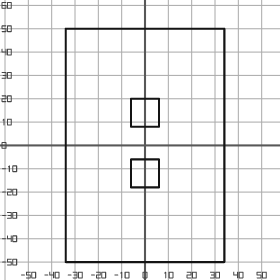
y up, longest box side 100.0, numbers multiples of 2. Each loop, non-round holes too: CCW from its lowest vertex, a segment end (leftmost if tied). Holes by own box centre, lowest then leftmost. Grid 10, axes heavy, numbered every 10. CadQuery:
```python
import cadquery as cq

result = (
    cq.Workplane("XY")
    .moveTo(-34.0, -50.0)
    .lineTo(34.0, -50.0)
    .lineTo(34.0, 50.0)
    .lineTo(-34.0, 50.0)
    .close()
    .moveTo(-6.0, -18.0)
    .lineTo(6.0, -18.0)
    .lineTo(6.0, -6.0)
    .lineTo(-6.0, -6.0)
    .close()
    .moveTo(-6.0, 8.0)
    .lineTo(6.0, 8.0)
    .lineTo(6.0, 20.0)
    .lineTo(-6.0, 20.0)
    .close()
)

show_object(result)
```